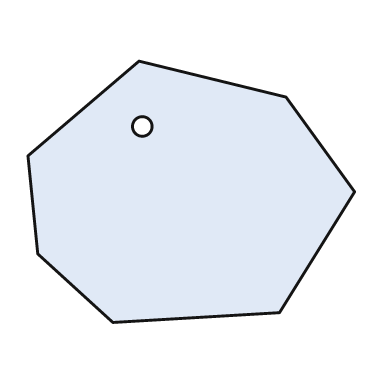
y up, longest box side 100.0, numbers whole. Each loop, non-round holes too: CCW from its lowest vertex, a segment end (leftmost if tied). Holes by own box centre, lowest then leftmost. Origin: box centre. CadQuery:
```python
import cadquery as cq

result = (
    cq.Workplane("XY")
    .moveTo(-24.0, -40.0)
    .lineTo(27.0, -37.0)
    .lineTo(50.0, 0.0)
    .lineTo(29.0, 29.0)
    .lineTo(-16.0, 40.0)
    .lineTo(-50.0, 11.0)
    .lineTo(-47.0, -19.0)
    .close()
    .moveTo(-15.0, 20.0)
    .circle(3.0)
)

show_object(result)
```